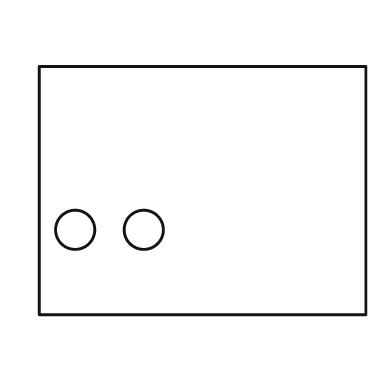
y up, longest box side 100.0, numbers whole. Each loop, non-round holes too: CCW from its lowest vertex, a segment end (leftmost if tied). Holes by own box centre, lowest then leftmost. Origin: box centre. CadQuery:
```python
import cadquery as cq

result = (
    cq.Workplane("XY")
    .moveTo(-50.0, -38.0)
    .lineTo(50.0, -38.0)
    .lineTo(50.0, 38.0)
    .lineTo(-50.0, 38.0)
    .close()
    .moveTo(-39.0, -12.0)
    .circle(6.0)
    .moveTo(-18.0, -12.0)
    .circle(6.0)
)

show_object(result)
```